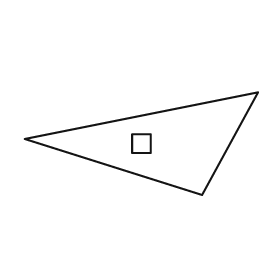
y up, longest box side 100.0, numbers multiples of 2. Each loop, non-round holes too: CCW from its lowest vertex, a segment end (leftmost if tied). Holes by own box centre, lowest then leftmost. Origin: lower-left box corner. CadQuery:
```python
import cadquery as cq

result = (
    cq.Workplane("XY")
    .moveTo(76.0, 0.0)
    .lineTo(100.0, 44.0)
    .lineTo(0.0, 24.0)
    .close()
    .moveTo(46.0, 18.0)
    .lineTo(54.0, 18.0)
    .lineTo(54.0, 26.0)
    .lineTo(46.0, 26.0)
    .close()
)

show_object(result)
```